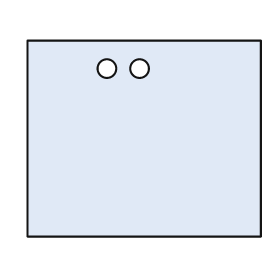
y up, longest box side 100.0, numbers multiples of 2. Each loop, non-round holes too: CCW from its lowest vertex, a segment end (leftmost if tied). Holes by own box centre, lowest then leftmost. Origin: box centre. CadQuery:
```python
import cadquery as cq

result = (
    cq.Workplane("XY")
    .moveTo(-50.0, -42.0)
    .lineTo(50.0, -42.0)
    .lineTo(50.0, 42.0)
    .lineTo(-50.0, 42.0)
    .close()
    .moveTo(-16.0, 30.0)
    .circle(4.0)
    .moveTo(-2.0, 30.0)
    .circle(4.0)
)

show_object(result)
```